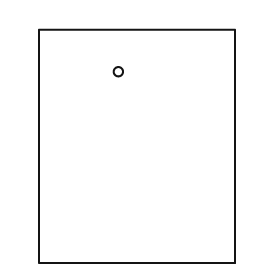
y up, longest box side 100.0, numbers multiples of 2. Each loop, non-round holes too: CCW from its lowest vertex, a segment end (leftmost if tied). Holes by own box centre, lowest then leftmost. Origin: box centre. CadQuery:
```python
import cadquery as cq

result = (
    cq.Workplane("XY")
    .moveTo(-42.0, -50.0)
    .lineTo(42.0, -50.0)
    .lineTo(42.0, 50.0)
    .lineTo(-42.0, 50.0)
    .close()
    .moveTo(-8.0, 32.0)
    .circle(2.0)
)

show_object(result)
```